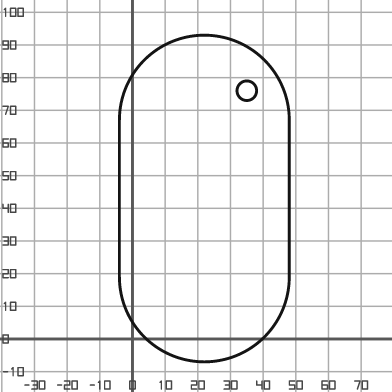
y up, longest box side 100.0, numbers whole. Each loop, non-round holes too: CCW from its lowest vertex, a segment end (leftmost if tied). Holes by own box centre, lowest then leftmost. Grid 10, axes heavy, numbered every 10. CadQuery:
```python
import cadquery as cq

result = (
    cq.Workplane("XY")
    .moveTo(-4.0, 19.0)
    .threePointArc((22.0, -7.0), (48.0, 19.0))
    .lineTo(48.0, 67.0)
    .threePointArc((22.0, 93.0), (-4.0, 67.0))
    .close()
    .moveTo(35.0, 76.0)
    .circle(3.0)
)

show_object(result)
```